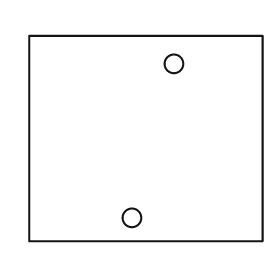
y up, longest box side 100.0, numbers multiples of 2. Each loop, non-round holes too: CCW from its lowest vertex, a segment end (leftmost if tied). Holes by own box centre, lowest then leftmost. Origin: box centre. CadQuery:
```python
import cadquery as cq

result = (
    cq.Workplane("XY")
    .moveTo(-50.0, -44.0)
    .lineTo(50.0, -44.0)
    .lineTo(50.0, 44.0)
    .lineTo(-50.0, 44.0)
    .close()
    .moveTo(-6.0, -34.0)
    .circle(4.0)
    .moveTo(12.0, 32.0)
    .circle(4.0)
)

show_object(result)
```